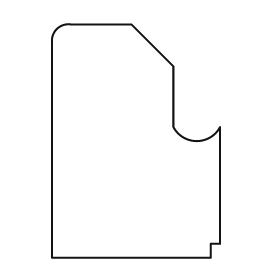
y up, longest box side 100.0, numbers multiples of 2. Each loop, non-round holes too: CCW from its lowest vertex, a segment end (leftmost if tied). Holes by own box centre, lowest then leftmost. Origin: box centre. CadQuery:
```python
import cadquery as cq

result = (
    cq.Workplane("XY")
    .moveTo(-36.0, -50.0)
    .lineTo(32.0, -50.0)
    .lineTo(32.0, -44.0)
    .lineTo(36.0, -44.0)
    .lineTo(36.0, 6.0)
    .threePointArc((26.0, 0.0), (16.0, 6.0))
    .lineTo(16.0, 32.0)
    .lineTo(-2.0, 50.0)
    .lineTo(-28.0, 50.0)
    .threePointArc((-34.0, 48.0), (-36.0, 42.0))
    .close()
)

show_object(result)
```